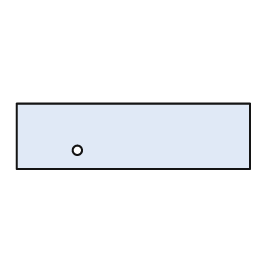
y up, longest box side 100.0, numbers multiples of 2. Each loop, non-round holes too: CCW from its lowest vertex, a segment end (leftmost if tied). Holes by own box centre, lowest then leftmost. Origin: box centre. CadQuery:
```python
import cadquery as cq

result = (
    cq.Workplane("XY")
    .moveTo(-50.0, -14.0)
    .lineTo(50.0, -14.0)
    .lineTo(50.0, 14.0)
    .lineTo(-50.0, 14.0)
    .close()
    .moveTo(-24.0, -6.0)
    .circle(2.0)
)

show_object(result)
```